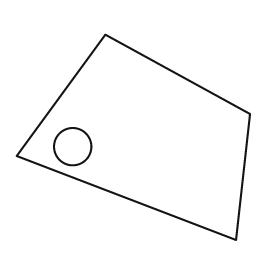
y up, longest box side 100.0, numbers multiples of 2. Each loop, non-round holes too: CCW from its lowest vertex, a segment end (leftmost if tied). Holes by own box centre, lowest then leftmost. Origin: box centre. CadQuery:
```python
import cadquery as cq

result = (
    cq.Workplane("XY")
    .moveTo(44.0, -44.0)
    .lineTo(50.0, 10.0)
    .lineTo(-12.0, 44.0)
    .lineTo(-50.0, -8.0)
    .close()
    .moveTo(-26.0, -4.0)
    .circle(8.0)
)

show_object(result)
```